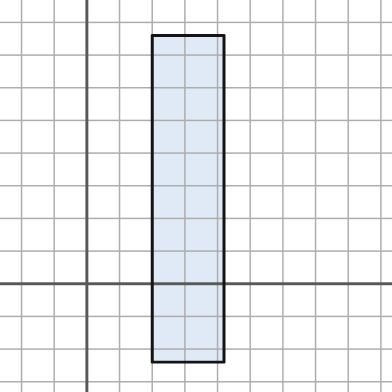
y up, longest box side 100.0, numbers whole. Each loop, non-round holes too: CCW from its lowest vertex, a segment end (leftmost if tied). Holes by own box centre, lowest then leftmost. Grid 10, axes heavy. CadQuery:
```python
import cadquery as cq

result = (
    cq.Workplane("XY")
    .moveTo(20.0, -24.0)
    .lineTo(42.0, -24.0)
    .lineTo(42.0, 76.0)
    .lineTo(20.0, 76.0)
    .close()
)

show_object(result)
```